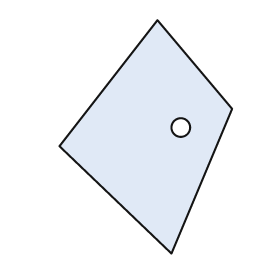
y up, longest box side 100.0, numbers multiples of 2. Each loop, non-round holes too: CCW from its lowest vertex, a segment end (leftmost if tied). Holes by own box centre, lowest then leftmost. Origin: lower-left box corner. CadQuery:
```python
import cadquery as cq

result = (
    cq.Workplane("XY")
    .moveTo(48.0, 0.0)
    .lineTo(74.0, 62.0)
    .lineTo(42.0, 100.0)
    .lineTo(0.0, 46.0)
    .close()
    .moveTo(52.0, 54.0)
    .circle(4.0)
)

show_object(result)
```